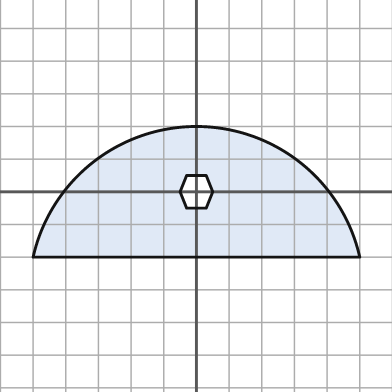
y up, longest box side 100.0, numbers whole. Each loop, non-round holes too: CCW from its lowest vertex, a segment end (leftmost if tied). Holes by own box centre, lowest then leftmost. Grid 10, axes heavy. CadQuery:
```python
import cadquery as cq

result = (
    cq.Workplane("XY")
    .moveTo(-50.0, -20.0)
    .lineTo(50.0, -20.0)
    .threePointArc((0.0, 20.0), (-50.0, -20.0))
    .close()
    .moveTo(-3.0, -5.0)
    .lineTo(3.0, -5.0)
    .lineTo(5.0, 0.0)
    .lineTo(3.0, 5.0)
    .lineTo(-3.0, 5.0)
    .lineTo(-5.0, 0.0)
    .close()
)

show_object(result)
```